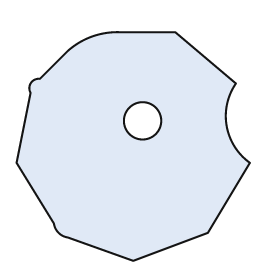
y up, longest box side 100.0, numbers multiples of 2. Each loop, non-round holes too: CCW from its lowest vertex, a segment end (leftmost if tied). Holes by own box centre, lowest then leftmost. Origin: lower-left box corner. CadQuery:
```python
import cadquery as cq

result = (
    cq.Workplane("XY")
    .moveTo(50.0, 0.0)
    .lineTo(82.0, 12.0)
    .lineTo(100.0, 42.0)
    .threePointArc((90.0, 58.0), (94.0, 76.0))
    .lineTo(68.0, 98.0)
    .lineTo(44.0, 98.0)
    .threePointArc((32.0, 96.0), (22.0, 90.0))
    .lineTo(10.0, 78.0)
    .threePointArc((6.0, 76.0), (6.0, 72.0))
    .lineTo(0.0, 42.0)
    .lineTo(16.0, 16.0)
    .threePointArc((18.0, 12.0), (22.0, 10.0))
    .close()
    .moveTo(54.0, 60.0)
    .circle(8.0)
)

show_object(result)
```